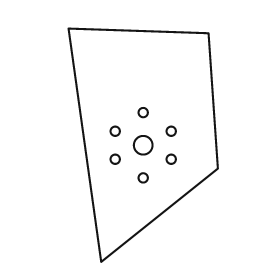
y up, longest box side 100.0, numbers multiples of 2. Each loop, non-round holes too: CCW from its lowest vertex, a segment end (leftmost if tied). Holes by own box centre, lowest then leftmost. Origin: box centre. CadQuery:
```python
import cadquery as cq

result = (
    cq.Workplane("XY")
    .moveTo(-18.0, -50.0)
    .lineTo(32.0, -10.0)
    .lineTo(28.0, 48.0)
    .lineTo(-32.0, 50.0)
    .close()
    .moveTo(0.0, -14.0)
    .circle(2.0)
    .moveTo(-12.0, -6.0)
    .circle(2.0)
    .moveTo(12.0, -6.0)
    .circle(2.0)
    .moveTo(0.0, 0.0)
    .circle(4.0)
    .moveTo(-12.0, 6.0)
    .circle(2.0)
    .moveTo(12.0, 6.0)
    .circle(2.0)
    .moveTo(0.0, 14.0)
    .circle(2.0)
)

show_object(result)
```